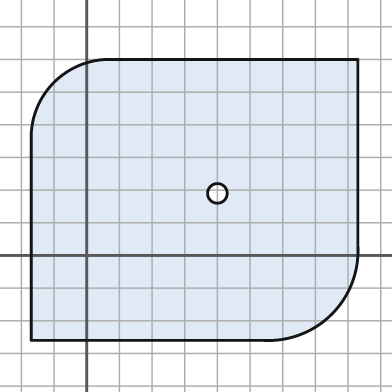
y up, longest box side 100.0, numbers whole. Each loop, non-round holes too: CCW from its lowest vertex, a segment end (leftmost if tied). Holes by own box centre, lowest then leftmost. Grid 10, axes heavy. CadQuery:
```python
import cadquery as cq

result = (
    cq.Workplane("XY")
    .moveTo(-17.0, -26.0)
    .lineTo(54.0, -26.0)
    .threePointArc((75.0, -18.0), (83.0, 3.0))
    .lineTo(83.0, 60.0)
    .lineTo(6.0, 60.0)
    .threePointArc((-10.0, 53.0), (-17.0, 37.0))
    .close()
    .moveTo(40.0, 19.0)
    .circle(3.0)
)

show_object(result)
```